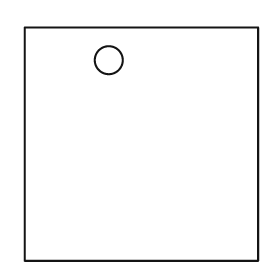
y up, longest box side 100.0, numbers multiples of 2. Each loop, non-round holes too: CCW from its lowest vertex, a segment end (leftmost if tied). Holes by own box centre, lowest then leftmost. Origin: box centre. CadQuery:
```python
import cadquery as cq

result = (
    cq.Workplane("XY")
    .moveTo(-50.0, -50.0)
    .lineTo(50.0, -50.0)
    .lineTo(50.0, 50.0)
    .lineTo(-50.0, 50.0)
    .close()
    .moveTo(-14.0, 36.0)
    .circle(6.0)
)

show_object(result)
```